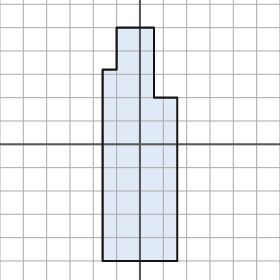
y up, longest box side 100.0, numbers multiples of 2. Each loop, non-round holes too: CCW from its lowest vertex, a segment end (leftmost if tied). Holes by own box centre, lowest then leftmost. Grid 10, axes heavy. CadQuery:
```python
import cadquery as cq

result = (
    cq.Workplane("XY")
    .moveTo(-16.0, -50.0)
    .lineTo(16.0, -50.0)
    .lineTo(16.0, 20.0)
    .lineTo(6.0, 20.0)
    .lineTo(6.0, 50.0)
    .lineTo(-10.0, 50.0)
    .lineTo(-10.0, 32.0)
    .lineTo(-16.0, 32.0)
    .close()
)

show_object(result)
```